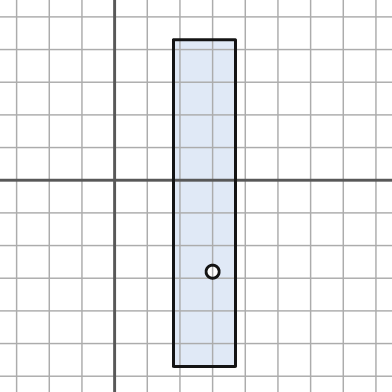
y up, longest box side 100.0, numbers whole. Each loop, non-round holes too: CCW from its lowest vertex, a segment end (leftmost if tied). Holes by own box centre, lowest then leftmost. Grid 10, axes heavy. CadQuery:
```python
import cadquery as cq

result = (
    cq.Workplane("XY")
    .moveTo(18.0, -57.0)
    .lineTo(37.0, -57.0)
    .lineTo(37.0, 43.0)
    .lineTo(18.0, 43.0)
    .close()
    .moveTo(30.0, -28.0)
    .circle(2.0)
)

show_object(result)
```